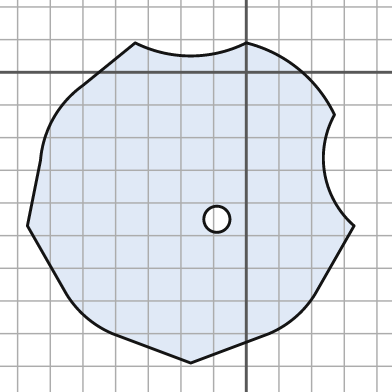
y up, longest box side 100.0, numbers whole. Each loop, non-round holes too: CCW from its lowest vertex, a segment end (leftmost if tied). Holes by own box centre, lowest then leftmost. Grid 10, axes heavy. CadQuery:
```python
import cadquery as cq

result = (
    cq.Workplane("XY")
    .moveTo(-17.0, -89.0)
    .lineTo(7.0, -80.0)
    .threePointArc((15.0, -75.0), (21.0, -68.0))
    .lineTo(33.0, -47.0)
    .threePointArc((24.0, -31.0), (27.0, -13.0))
    .threePointArc((16.0, 1.0), (0.0, 9.0))
    .threePointArc((-17.0, 5.0), (-34.0, 9.0))
    .lineTo(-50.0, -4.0)
    .threePointArc((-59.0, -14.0), (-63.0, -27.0))
    .lineTo(-67.0, -47.0)
    .lineTo(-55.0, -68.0)
    .threePointArc((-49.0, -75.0), (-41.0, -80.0))
    .close()
    .moveTo(-9.0, -45.0)
    .circle(4.0)
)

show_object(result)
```